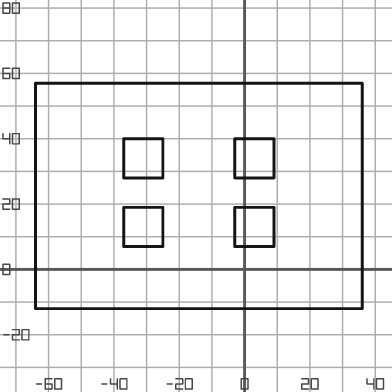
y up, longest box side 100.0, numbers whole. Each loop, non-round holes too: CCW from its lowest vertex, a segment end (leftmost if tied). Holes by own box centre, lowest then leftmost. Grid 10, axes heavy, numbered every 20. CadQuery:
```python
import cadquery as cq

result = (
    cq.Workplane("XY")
    .moveTo(-64.0, -12.0)
    .lineTo(36.0, -12.0)
    .lineTo(36.0, 57.0)
    .lineTo(-64.0, 57.0)
    .close()
    .moveTo(-37.0, 7.0)
    .lineTo(-25.0, 7.0)
    .lineTo(-25.0, 19.0)
    .lineTo(-37.0, 19.0)
    .close()
    .moveTo(-3.0, 7.0)
    .lineTo(9.0, 7.0)
    .lineTo(9.0, 19.0)
    .lineTo(-3.0, 19.0)
    .close()
    .moveTo(-37.0, 28.0)
    .lineTo(-25.0, 28.0)
    .lineTo(-25.0, 40.0)
    .lineTo(-37.0, 40.0)
    .close()
    .moveTo(-3.0, 28.0)
    .lineTo(9.0, 28.0)
    .lineTo(9.0, 40.0)
    .lineTo(-3.0, 40.0)
    .close()
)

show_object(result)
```